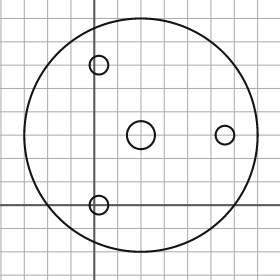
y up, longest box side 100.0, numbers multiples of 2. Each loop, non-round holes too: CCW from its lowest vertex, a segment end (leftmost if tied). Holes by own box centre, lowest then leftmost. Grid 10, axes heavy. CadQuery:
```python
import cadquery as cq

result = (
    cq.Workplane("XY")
    .moveTo(20.0, 30.0)
    .circle(50.0)
    .moveTo(2.0, 0.0)
    .circle(4.0)
    .moveTo(20.0, 30.0)
    .circle(6.0)
    .moveTo(56.0, 30.0)
    .circle(4.0)
    .moveTo(2.0, 60.0)
    .circle(4.0)
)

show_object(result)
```